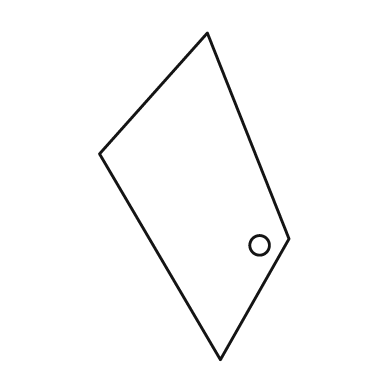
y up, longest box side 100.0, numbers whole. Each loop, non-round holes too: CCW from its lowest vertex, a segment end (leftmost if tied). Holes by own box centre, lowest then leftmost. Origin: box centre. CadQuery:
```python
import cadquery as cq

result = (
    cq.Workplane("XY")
    .moveTo(8.0, -50.0)
    .lineTo(29.0, -13.0)
    .lineTo(4.0, 50.0)
    .lineTo(-29.0, 13.0)
    .close()
    .moveTo(20.0, -15.0)
    .circle(3.0)
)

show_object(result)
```